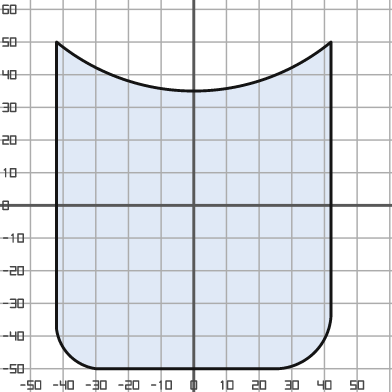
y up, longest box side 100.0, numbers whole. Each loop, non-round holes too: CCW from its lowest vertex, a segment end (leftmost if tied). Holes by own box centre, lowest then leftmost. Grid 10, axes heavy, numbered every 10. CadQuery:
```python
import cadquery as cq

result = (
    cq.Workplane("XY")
    .moveTo(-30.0, -50.0)
    .lineTo(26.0, -50.0)
    .threePointArc((37.0, -45.0), (42.0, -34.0))
    .lineTo(42.0, 50.0)
    .threePointArc((0.0, 35.0), (-42.0, 50.0))
    .lineTo(-42.0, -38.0)
    .threePointArc((-38.0, -46.0), (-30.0, -50.0))
    .close()
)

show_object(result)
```